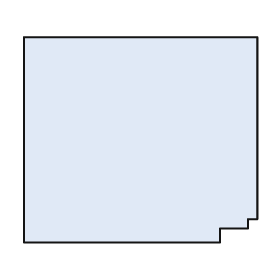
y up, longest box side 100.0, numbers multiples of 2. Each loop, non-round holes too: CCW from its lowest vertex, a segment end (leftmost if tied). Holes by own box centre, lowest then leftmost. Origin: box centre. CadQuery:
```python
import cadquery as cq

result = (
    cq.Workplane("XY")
    .moveTo(-50.0, -44.0)
    .lineTo(34.0, -44.0)
    .lineTo(34.0, -38.0)
    .lineTo(46.0, -38.0)
    .lineTo(46.0, -34.0)
    .lineTo(50.0, -34.0)
    .lineTo(50.0, 44.0)
    .lineTo(-50.0, 44.0)
    .close()
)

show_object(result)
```